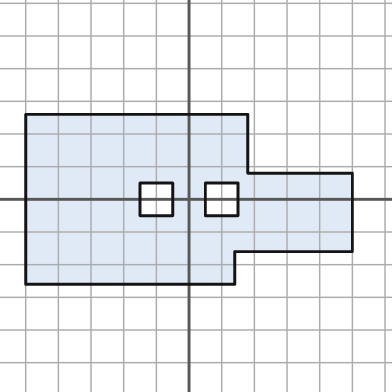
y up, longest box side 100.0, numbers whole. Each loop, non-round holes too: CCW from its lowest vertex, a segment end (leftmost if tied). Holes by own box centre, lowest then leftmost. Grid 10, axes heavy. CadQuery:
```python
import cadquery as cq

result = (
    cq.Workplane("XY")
    .moveTo(-50.0, -26.0)
    .lineTo(14.0, -26.0)
    .lineTo(14.0, -16.0)
    .lineTo(50.0, -16.0)
    .lineTo(50.0, 8.0)
    .lineTo(18.0, 8.0)
    .lineTo(18.0, 26.0)
    .lineTo(-50.0, 26.0)
    .close()
    .moveTo(-15.0, -5.0)
    .lineTo(-5.0, -5.0)
    .lineTo(-5.0, 5.0)
    .lineTo(-15.0, 5.0)
    .close()
    .moveTo(5.0, -5.0)
    .lineTo(15.0, -5.0)
    .lineTo(15.0, 5.0)
    .lineTo(5.0, 5.0)
    .close()
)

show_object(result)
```